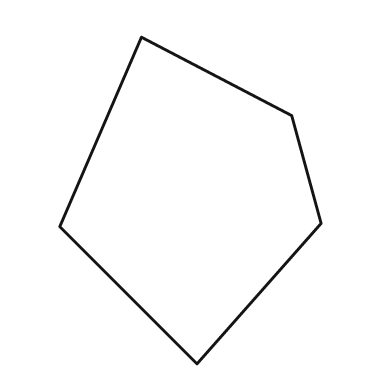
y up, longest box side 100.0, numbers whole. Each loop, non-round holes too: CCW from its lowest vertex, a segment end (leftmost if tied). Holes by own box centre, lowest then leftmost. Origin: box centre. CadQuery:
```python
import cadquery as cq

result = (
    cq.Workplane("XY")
    .moveTo(2.0, -50.0)
    .lineTo(40.0, -7.0)
    .lineTo(31.0, 26.0)
    .lineTo(-15.0, 50.0)
    .lineTo(-40.0, -8.0)
    .close()
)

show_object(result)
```